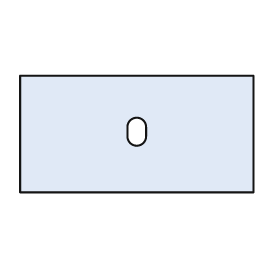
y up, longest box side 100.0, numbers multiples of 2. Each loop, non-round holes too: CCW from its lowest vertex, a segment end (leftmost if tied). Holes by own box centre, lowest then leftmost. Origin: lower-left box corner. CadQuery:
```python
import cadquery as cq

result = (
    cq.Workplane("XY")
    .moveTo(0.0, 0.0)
    .lineTo(100.0, 0.0)
    .lineTo(100.0, 50.0)
    .lineTo(0.0, 50.0)
    .close()
    .moveTo(46.0, 24.0)
    .threePointArc((50.0, 20.0), (54.0, 24.0))
    .lineTo(54.0, 28.0)
    .threePointArc((50.0, 32.0), (46.0, 28.0))
    .close()
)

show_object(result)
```